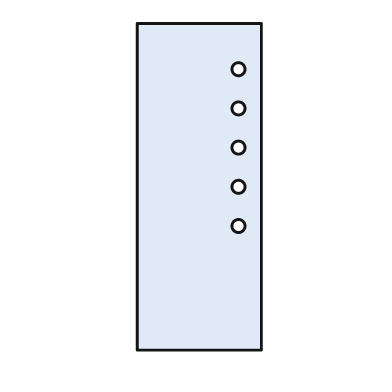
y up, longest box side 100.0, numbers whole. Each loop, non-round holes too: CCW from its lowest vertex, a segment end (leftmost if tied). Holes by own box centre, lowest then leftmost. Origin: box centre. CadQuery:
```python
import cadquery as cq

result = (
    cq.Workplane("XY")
    .moveTo(-19.0, -50.0)
    .lineTo(19.0, -50.0)
    .lineTo(19.0, 50.0)
    .lineTo(-19.0, 50.0)
    .close()
    .moveTo(12.0, -12.0)
    .circle(2.0)
    .moveTo(12.0, 0.0)
    .circle(2.0)
    .moveTo(12.0, 12.0)
    .circle(2.0)
    .moveTo(12.0, 24.0)
    .circle(2.0)
    .moveTo(12.0, 36.0)
    .circle(2.0)
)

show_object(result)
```